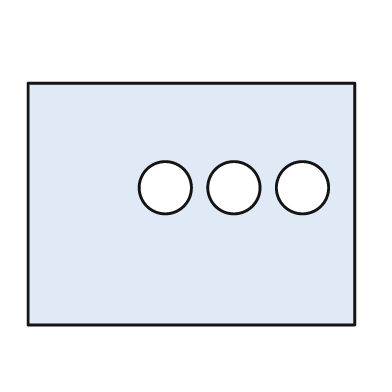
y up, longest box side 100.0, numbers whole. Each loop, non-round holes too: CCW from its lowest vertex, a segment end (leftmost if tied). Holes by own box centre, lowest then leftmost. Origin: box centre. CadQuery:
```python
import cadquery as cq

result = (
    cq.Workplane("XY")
    .moveTo(-50.0, -37.0)
    .lineTo(50.0, -37.0)
    .lineTo(50.0, 37.0)
    .lineTo(-50.0, 37.0)
    .close()
    .moveTo(-8.0, 5.0)
    .circle(8.0)
    .moveTo(13.0, 5.0)
    .circle(8.0)
    .moveTo(34.0, 5.0)
    .circle(8.0)
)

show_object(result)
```